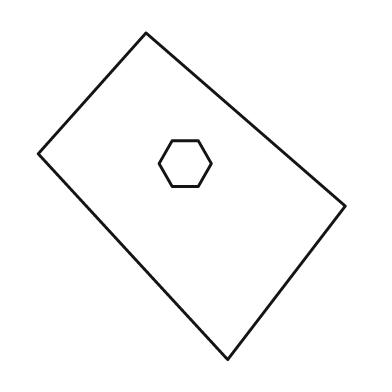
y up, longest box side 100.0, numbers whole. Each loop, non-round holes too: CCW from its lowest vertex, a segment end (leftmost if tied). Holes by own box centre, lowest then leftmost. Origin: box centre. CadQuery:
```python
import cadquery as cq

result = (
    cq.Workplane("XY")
    .moveTo(11.0, -50.0)
    .lineTo(47.0, -3.0)
    .lineTo(-14.0, 50.0)
    .lineTo(-47.0, 13.0)
    .close()
    .moveTo(-6.0, 3.0)
    .lineTo(2.0, 3.0)
    .lineTo(6.0, 10.0)
    .lineTo(2.0, 17.0)
    .lineTo(-6.0, 17.0)
    .lineTo(-10.0, 10.0)
    .close()
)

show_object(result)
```